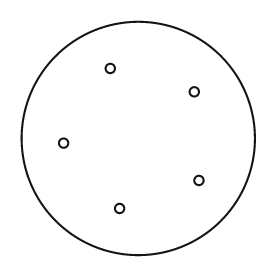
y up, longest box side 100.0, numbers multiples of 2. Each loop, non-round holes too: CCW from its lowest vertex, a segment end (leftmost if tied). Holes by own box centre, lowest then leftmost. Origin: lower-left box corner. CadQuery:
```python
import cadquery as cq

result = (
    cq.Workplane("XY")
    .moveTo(50.0, 50.0)
    .circle(50.0)
    .moveTo(42.0, 20.0)
    .circle(2.0)
    .moveTo(76.0, 32.0)
    .circle(2.0)
    .moveTo(18.0, 48.0)
    .circle(2.0)
    .moveTo(74.0, 70.0)
    .circle(2.0)
    .moveTo(38.0, 80.0)
    .circle(2.0)
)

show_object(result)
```